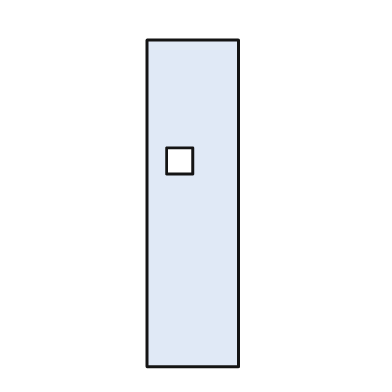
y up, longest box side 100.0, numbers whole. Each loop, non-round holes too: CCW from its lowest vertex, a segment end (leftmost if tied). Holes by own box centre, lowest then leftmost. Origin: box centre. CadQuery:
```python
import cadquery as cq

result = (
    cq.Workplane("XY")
    .moveTo(-14.0, -50.0)
    .lineTo(14.0, -50.0)
    .lineTo(14.0, 50.0)
    .lineTo(-14.0, 50.0)
    .close()
    .moveTo(-8.0, 9.0)
    .lineTo(0.0, 9.0)
    .lineTo(0.0, 17.0)
    .lineTo(-8.0, 17.0)
    .close()
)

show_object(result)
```